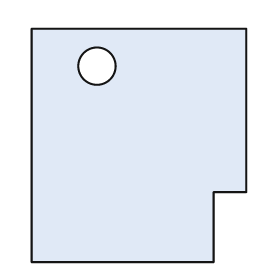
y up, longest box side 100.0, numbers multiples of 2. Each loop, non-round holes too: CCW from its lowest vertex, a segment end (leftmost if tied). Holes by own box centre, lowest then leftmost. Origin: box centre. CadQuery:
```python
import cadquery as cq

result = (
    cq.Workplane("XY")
    .moveTo(-46.0, -50.0)
    .lineTo(32.0, -50.0)
    .lineTo(32.0, -20.0)
    .lineTo(46.0, -20.0)
    .lineTo(46.0, 50.0)
    .lineTo(-46.0, 50.0)
    .close()
    .moveTo(-18.0, 34.0)
    .circle(8.0)
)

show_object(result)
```